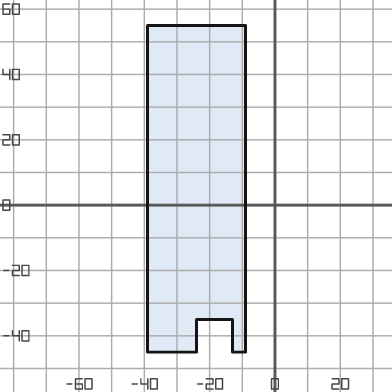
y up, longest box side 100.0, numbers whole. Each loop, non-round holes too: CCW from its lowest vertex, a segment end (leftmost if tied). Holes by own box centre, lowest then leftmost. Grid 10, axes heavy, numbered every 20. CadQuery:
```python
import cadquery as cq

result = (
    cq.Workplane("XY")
    .moveTo(-39.0, -45.0)
    .lineTo(-24.0, -45.0)
    .lineTo(-24.0, -35.0)
    .lineTo(-13.0, -35.0)
    .lineTo(-13.0, -45.0)
    .lineTo(-9.0, -45.0)
    .lineTo(-9.0, 55.0)
    .lineTo(-39.0, 55.0)
    .close()
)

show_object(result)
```